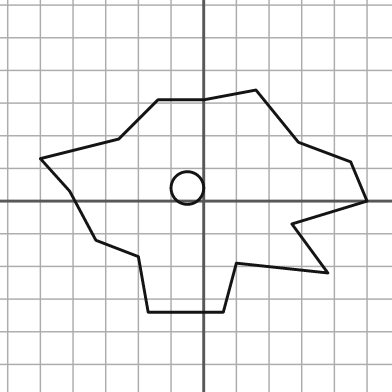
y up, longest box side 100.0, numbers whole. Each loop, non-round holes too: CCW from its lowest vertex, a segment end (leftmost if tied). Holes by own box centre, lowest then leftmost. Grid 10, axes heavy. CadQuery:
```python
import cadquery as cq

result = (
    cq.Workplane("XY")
    .moveTo(-17.0, -34.0)
    .lineTo(6.0, -34.0)
    .lineTo(10.0, -19.0)
    .lineTo(38.0, -22.0)
    .lineTo(27.0, -7.0)
    .lineTo(50.0, 0.0)
    .lineTo(45.0, 12.0)
    .lineTo(29.0, 18.0)
    .lineTo(16.0, 34.0)
    .lineTo(0.0, 31.0)
    .lineTo(-14.0, 31.0)
    .lineTo(-26.0, 19.0)
    .lineTo(-50.0, 13.0)
    .lineTo(-41.0, 3.0)
    .lineTo(-33.0, -12.0)
    .lineTo(-20.0, -17.0)
    .close()
    .moveTo(-5.0, 4.0)
    .circle(5.0)
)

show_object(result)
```